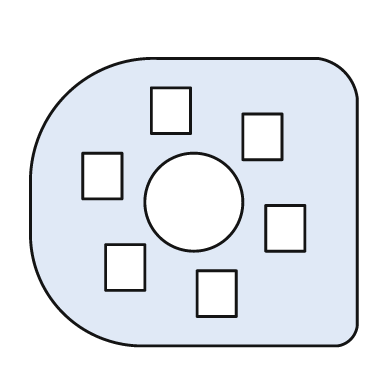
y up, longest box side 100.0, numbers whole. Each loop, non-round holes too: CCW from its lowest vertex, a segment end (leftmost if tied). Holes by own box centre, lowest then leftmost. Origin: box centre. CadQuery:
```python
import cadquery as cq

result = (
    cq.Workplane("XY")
    .moveTo(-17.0, -44.0)
    .lineTo(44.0, -44.0)
    .threePointArc((48.0, -42.0), (50.0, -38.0))
    .lineTo(50.0, 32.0)
    .threePointArc((46.0, 40.0), (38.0, 44.0))
    .lineTo(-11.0, 44.0)
    .threePointArc((-39.0, 33.0), (-50.0, 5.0))
    .lineTo(-50.0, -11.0)
    .threePointArc((-40.0, -34.0), (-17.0, -44.0))
    .close()
    .moveTo(1.0, -35.0)
    .lineTo(13.0, -35.0)
    .lineTo(13.0, -21.0)
    .lineTo(1.0, -21.0)
    .close()
    .moveTo(-27.0, -27.0)
    .lineTo(-15.0, -27.0)
    .lineTo(-15.0, -13.0)
    .lineTo(-27.0, -13.0)
    .close()
    .moveTo(22.0, -15.0)
    .lineTo(34.0, -15.0)
    .lineTo(34.0, -1.0)
    .lineTo(22.0, -1.0)
    .close()
    .moveTo(0.0, 0.0)
    .circle(15.0)
    .moveTo(-34.0, 1.0)
    .lineTo(-22.0, 1.0)
    .lineTo(-22.0, 15.0)
    .lineTo(-34.0, 15.0)
    .close()
    .moveTo(15.0, 13.0)
    .lineTo(27.0, 13.0)
    .lineTo(27.0, 27.0)
    .lineTo(15.0, 27.0)
    .close()
    .moveTo(-13.0, 21.0)
    .lineTo(-1.0, 21.0)
    .lineTo(-1.0, 35.0)
    .lineTo(-13.0, 35.0)
    .close()
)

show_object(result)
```